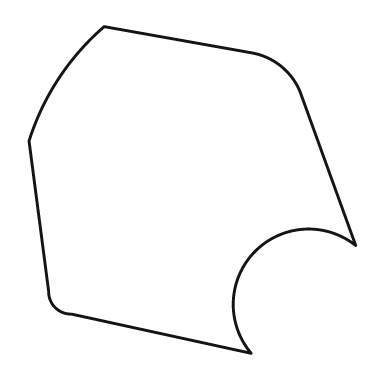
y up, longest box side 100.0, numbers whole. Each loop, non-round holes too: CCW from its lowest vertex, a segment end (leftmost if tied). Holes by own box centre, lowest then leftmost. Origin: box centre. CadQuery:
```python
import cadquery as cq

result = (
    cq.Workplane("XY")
    .moveTo(18.0, -50.0)
    .threePointArc((19.0, -19.0), (50.0, -17.0))
    .lineTo(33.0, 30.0)
    .threePointArc((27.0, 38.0), (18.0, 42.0))
    .lineTo(-27.0, 50.0)
    .threePointArc((-41.0, 34.0), (-50.0, 15.0))
    .lineTo(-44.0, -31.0)
    .threePointArc((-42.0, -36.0), (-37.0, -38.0))
    .close()
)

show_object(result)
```